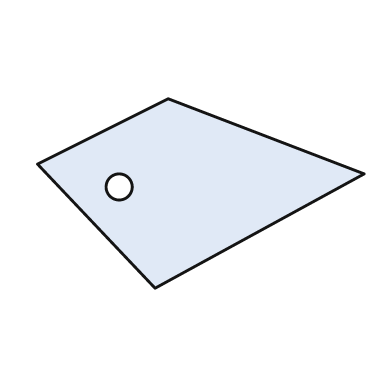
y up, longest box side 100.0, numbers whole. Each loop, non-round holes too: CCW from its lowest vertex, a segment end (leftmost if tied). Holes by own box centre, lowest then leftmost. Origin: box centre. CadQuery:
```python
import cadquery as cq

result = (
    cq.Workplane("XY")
    .moveTo(-14.0, -29.0)
    .lineTo(50.0, 6.0)
    .lineTo(-10.0, 29.0)
    .lineTo(-50.0, 9.0)
    .close()
    .moveTo(-25.0, 2.0)
    .circle(4.0)
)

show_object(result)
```